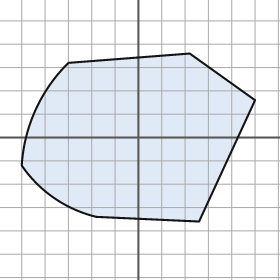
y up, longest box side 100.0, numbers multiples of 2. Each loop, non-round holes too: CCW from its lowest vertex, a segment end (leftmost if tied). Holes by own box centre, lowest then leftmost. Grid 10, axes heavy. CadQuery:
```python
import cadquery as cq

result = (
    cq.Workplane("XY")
    .moveTo(26.0, -36.0)
    .lineTo(50.0, 16.0)
    .lineTo(22.0, 36.0)
    .lineTo(-30.0, 32.0)
    .threePointArc((-44.0, 12.0), (-50.0, -12.0))
    .threePointArc((-36.0, -26.0), (-18.0, -34.0))
    .close()
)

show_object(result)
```